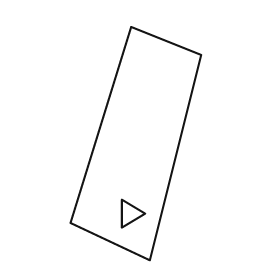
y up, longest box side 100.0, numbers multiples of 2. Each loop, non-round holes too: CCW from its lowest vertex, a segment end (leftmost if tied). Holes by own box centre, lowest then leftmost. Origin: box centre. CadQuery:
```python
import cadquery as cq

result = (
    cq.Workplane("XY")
    .moveTo(6.0, -50.0)
    .lineTo(28.0, 38.0)
    .lineTo(-2.0, 50.0)
    .lineTo(-28.0, -34.0)
    .close()
    .moveTo(-6.0, -36.0)
    .lineTo(4.0, -30.0)
    .lineTo(-6.0, -24.0)
    .close()
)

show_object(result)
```